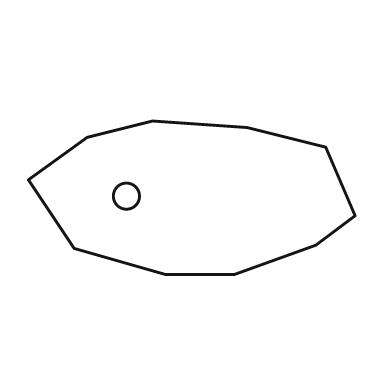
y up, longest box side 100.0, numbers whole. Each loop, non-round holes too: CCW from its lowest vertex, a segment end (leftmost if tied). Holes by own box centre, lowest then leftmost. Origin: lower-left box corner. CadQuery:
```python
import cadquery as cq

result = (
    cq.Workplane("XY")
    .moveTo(42.0, 0.0)
    .lineTo(63.0, 0.0)
    .lineTo(88.0, 9.0)
    .lineTo(100.0, 18.0)
    .lineTo(91.0, 39.0)
    .lineTo(67.0, 45.0)
    .lineTo(38.0, 47.0)
    .lineTo(18.0, 42.0)
    .lineTo(0.0, 29.0)
    .lineTo(14.0, 8.0)
    .close()
    .moveTo(30.0, 24.0)
    .circle(4.0)
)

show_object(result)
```